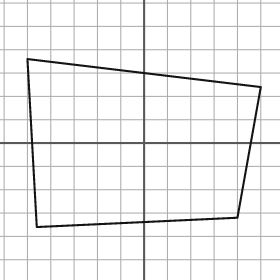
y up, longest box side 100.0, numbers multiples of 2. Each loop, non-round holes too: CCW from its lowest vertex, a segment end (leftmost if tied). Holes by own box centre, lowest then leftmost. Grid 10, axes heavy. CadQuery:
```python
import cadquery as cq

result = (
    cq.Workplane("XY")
    .moveTo(-46.0, -36.0)
    .lineTo(40.0, -32.0)
    .lineTo(50.0, 24.0)
    .lineTo(-50.0, 36.0)
    .close()
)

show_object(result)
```